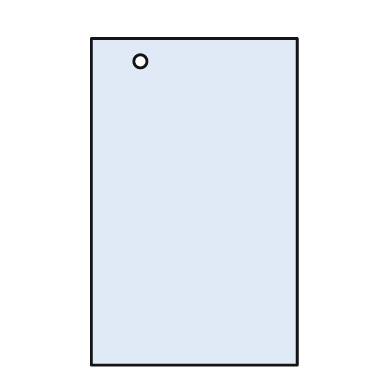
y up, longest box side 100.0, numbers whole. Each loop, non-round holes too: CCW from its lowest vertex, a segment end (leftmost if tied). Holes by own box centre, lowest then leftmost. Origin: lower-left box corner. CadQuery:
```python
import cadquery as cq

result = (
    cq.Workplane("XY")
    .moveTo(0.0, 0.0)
    .lineTo(63.0, 0.0)
    .lineTo(63.0, 100.0)
    .lineTo(0.0, 100.0)
    .close()
    .moveTo(15.0, 93.0)
    .circle(2.0)
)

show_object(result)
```